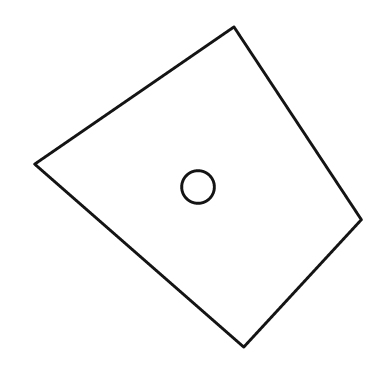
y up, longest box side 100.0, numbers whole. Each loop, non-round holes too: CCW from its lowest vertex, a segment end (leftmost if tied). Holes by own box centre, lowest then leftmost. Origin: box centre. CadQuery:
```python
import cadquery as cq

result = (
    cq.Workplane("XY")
    .moveTo(14.0, -49.0)
    .lineTo(50.0, -10.0)
    .lineTo(11.0, 49.0)
    .lineTo(-50.0, 7.0)
    .close()
    .moveTo(0.0, 0.0)
    .circle(5.0)
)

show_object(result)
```